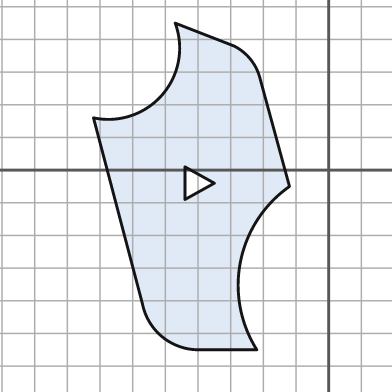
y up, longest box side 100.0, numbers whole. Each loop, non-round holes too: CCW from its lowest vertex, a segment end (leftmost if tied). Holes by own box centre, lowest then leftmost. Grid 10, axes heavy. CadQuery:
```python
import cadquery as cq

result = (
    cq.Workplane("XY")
    .moveTo(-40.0, -55.0)
    .lineTo(-22.0, -55.0)
    .threePointArc((-27.0, -28.0), (-12.0, -5.0))
    .lineTo(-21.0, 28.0)
    .threePointArc((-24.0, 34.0), (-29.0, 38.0))
    .lineTo(-47.0, 45.0)
    .threePointArc((-51.0, 23.0), (-72.0, 16.0))
    .lineTo(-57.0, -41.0)
    .threePointArc((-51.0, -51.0), (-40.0, -55.0))
    .close()
    .moveTo(-44.0, -9.0)
    .lineTo(-35.0, -4.0)
    .lineTo(-44.0, 1.0)
    .close()
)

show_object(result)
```